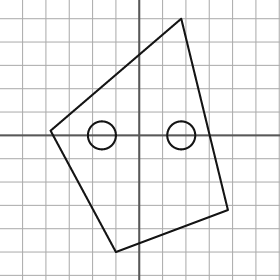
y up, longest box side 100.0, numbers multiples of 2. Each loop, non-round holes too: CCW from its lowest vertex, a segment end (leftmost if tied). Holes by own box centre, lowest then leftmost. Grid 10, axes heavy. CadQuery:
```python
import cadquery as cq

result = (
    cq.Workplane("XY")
    .moveTo(-10.0, -50.0)
    .lineTo(38.0, -32.0)
    .lineTo(18.0, 50.0)
    .lineTo(-38.0, 2.0)
    .close()
    .moveTo(-16.0, 0.0)
    .circle(6.0)
    .moveTo(18.0, 0.0)
    .circle(6.0)
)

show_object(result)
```